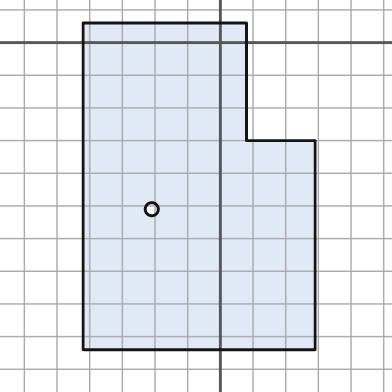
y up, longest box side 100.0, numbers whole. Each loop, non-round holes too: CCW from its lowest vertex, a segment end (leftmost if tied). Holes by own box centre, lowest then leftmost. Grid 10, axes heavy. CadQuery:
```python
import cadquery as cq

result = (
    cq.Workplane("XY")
    .moveTo(-42.0, -94.0)
    .lineTo(29.0, -94.0)
    .lineTo(29.0, -30.0)
    .lineTo(8.0, -30.0)
    .lineTo(8.0, 6.0)
    .lineTo(-42.0, 6.0)
    .close()
    .moveTo(-21.0, -51.0)
    .circle(2.0)
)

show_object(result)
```